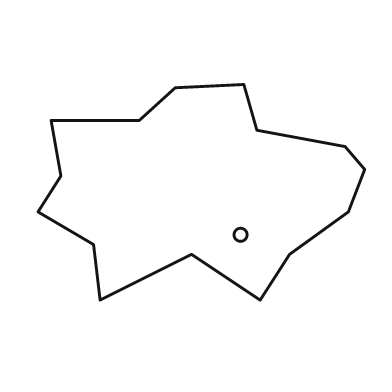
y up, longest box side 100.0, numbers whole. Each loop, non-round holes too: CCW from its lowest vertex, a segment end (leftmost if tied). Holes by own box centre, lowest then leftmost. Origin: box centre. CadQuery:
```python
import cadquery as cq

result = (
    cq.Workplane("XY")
    .moveTo(-31.0, -33.0)
    .lineTo(-3.0, -19.0)
    .lineTo(18.0, -33.0)
    .lineTo(27.0, -19.0)
    .lineTo(45.0, -6.0)
    .lineTo(50.0, 7.0)
    .lineTo(44.0, 14.0)
    .lineTo(17.0, 19.0)
    .lineTo(13.0, 33.0)
    .lineTo(-8.0, 32.0)
    .lineTo(-19.0, 22.0)
    .lineTo(-46.0, 22.0)
    .lineTo(-43.0, 5.0)
    .lineTo(-50.0, -6.0)
    .lineTo(-33.0, -16.0)
    .close()
    .moveTo(12.0, -13.0)
    .circle(2.0)
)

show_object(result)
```